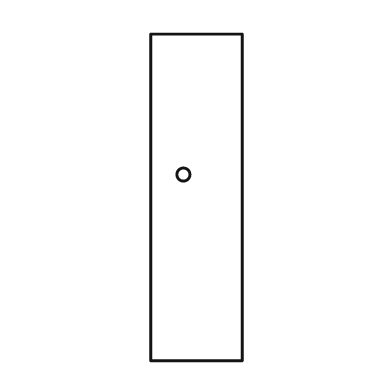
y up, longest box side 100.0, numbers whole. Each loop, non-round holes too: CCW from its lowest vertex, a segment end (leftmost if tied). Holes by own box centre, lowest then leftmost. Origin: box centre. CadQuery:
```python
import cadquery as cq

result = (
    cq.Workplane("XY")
    .moveTo(-14.0, -50.0)
    .lineTo(14.0, -50.0)
    .lineTo(14.0, 50.0)
    .lineTo(-14.0, 50.0)
    .close()
    .moveTo(-4.0, 7.0)
    .circle(2.0)
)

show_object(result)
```